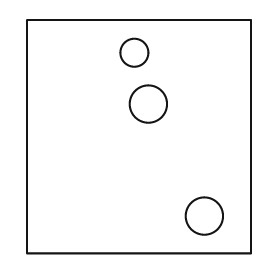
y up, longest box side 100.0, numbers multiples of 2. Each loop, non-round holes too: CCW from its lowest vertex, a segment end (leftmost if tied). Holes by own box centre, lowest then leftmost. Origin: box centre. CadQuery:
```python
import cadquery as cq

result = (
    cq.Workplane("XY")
    .moveTo(-48.0, -50.0)
    .lineTo(48.0, -50.0)
    .lineTo(48.0, 50.0)
    .lineTo(-48.0, 50.0)
    .close()
    .moveTo(28.0, -34.0)
    .circle(8.0)
    .moveTo(4.0, 14.0)
    .circle(8.0)
    .moveTo(-2.0, 36.0)
    .circle(6.0)
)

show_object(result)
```